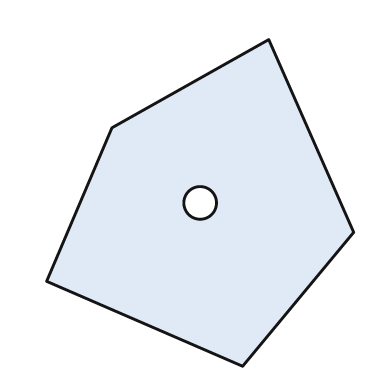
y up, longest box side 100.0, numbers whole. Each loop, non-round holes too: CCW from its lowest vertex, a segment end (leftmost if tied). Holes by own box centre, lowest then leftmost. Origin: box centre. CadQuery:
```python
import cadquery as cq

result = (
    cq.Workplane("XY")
    .moveTo(13.0, -50.0)
    .lineTo(47.0, -9.0)
    .lineTo(21.0, 50.0)
    .lineTo(-27.0, 23.0)
    .lineTo(-47.0, -24.0)
    .close()
    .moveTo(0.0, 0.0)
    .circle(5.0)
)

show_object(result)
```